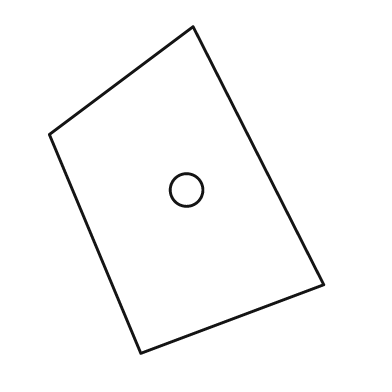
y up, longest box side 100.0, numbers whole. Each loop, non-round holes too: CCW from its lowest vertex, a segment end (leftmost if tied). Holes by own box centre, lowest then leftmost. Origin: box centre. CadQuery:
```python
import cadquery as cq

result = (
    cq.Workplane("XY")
    .moveTo(-14.0, -50.0)
    .lineTo(42.0, -29.0)
    .lineTo(2.0, 50.0)
    .lineTo(-42.0, 17.0)
    .close()
    .moveTo(0.0, 0.0)
    .circle(5.0)
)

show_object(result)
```